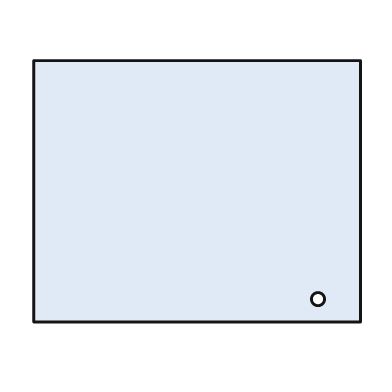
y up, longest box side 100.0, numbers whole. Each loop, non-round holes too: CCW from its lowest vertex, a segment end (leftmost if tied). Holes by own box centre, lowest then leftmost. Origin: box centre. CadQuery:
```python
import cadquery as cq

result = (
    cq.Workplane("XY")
    .moveTo(-50.0, -40.0)
    .lineTo(50.0, -40.0)
    .lineTo(50.0, 40.0)
    .lineTo(-50.0, 40.0)
    .close()
    .moveTo(37.0, -33.0)
    .circle(2.0)
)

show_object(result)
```